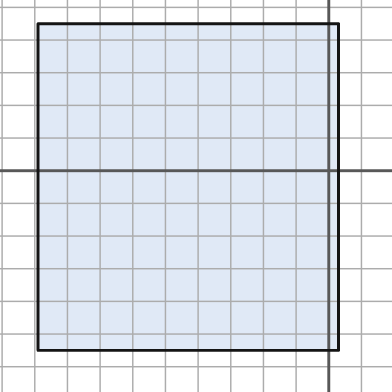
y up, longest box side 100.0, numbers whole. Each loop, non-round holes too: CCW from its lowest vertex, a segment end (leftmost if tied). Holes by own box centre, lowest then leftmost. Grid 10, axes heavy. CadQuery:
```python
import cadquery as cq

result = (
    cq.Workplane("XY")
    .moveTo(-89.0, -55.0)
    .lineTo(3.0, -55.0)
    .lineTo(3.0, 45.0)
    .lineTo(-89.0, 45.0)
    .close()
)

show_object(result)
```